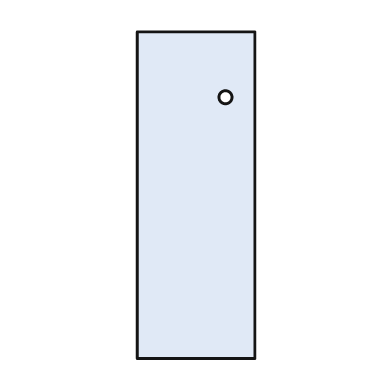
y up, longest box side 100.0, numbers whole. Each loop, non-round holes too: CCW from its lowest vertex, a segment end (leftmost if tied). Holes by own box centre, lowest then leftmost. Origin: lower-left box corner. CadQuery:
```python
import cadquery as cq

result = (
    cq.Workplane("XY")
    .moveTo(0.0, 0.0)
    .lineTo(36.0, 0.0)
    .lineTo(36.0, 100.0)
    .lineTo(0.0, 100.0)
    .close()
    .moveTo(27.0, 80.0)
    .circle(2.0)
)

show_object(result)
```